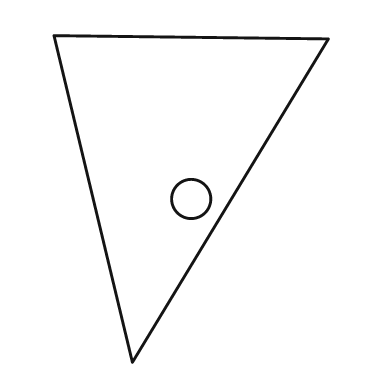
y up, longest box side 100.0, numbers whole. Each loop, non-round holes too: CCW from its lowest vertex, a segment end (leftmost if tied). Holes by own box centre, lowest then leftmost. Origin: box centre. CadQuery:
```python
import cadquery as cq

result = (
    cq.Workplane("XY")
    .moveTo(-18.0, -50.0)
    .lineTo(42.0, 49.0)
    .lineTo(-42.0, 50.0)
    .close()
    .moveTo(0.0, 0.0)
    .circle(6.0)
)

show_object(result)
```